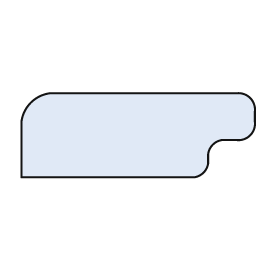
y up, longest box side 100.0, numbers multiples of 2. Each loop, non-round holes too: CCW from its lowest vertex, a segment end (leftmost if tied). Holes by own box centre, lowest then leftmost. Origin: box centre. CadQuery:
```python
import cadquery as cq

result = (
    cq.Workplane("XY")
    .moveTo(-50.0, -18.0)
    .lineTo(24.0, -18.0)
    .threePointArc((28.0, -16.0), (30.0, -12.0))
    .lineTo(30.0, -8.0)
    .threePointArc((32.0, -4.0), (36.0, -2.0))
    .lineTo(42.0, -2.0)
    .threePointArc((48.0, 0.0), (50.0, 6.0))
    .lineTo(50.0, 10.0)
    .threePointArc((48.0, 16.0), (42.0, 18.0))
    .lineTo(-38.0, 18.0)
    .threePointArc((-46.0, 14.0), (-50.0, 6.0))
    .close()
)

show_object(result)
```